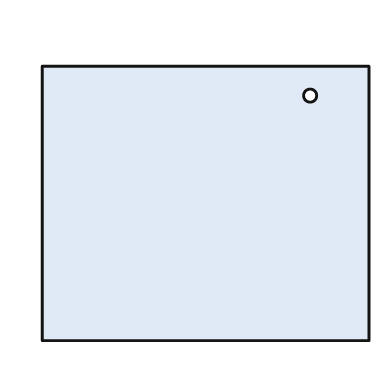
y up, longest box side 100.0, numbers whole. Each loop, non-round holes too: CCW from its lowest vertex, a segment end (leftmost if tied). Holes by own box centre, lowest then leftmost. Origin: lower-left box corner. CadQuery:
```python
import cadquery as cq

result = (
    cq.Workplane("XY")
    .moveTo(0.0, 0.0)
    .lineTo(100.0, 0.0)
    .lineTo(100.0, 84.0)
    .lineTo(0.0, 84.0)
    .close()
    .moveTo(82.0, 75.0)
    .circle(2.0)
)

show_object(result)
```